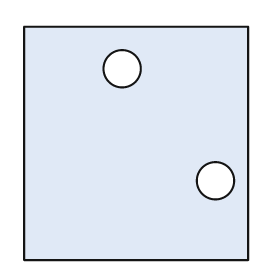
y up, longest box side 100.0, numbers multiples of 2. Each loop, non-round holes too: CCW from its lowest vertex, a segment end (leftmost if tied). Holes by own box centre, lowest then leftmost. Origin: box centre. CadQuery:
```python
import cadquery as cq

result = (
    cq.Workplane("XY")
    .moveTo(-48.0, -50.0)
    .lineTo(48.0, -50.0)
    .lineTo(48.0, 50.0)
    .lineTo(-48.0, 50.0)
    .close()
    .moveTo(34.0, -16.0)
    .circle(8.0)
    .moveTo(-6.0, 32.0)
    .circle(8.0)
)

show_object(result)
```